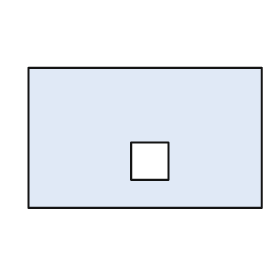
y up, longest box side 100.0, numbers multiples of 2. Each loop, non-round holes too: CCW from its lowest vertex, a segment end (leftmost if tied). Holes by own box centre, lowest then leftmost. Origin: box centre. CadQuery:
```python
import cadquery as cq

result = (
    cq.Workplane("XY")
    .moveTo(-50.0, -30.0)
    .lineTo(50.0, -30.0)
    .lineTo(50.0, 30.0)
    .lineTo(-50.0, 30.0)
    .close()
    .moveTo(-6.0, -18.0)
    .lineTo(10.0, -18.0)
    .lineTo(10.0, -2.0)
    .lineTo(-6.0, -2.0)
    .close()
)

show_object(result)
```